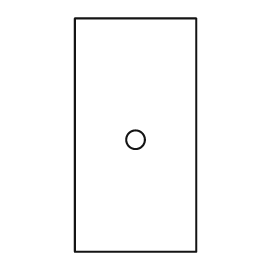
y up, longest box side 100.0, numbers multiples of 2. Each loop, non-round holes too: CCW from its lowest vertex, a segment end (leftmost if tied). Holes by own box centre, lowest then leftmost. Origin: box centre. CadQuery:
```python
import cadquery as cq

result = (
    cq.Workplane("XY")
    .moveTo(-26.0, -50.0)
    .lineTo(26.0, -50.0)
    .lineTo(26.0, 50.0)
    .lineTo(-26.0, 50.0)
    .close()
    .moveTo(0.0, -2.0)
    .circle(4.0)
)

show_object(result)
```